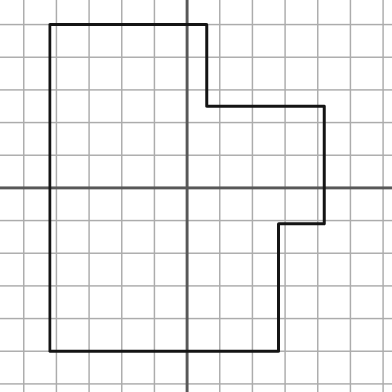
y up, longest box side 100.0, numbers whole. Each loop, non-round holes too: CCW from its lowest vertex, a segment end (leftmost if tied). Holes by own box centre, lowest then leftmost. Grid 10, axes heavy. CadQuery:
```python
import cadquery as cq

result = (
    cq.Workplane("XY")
    .moveTo(-42.0, -50.0)
    .lineTo(28.0, -50.0)
    .lineTo(28.0, -11.0)
    .lineTo(42.0, -11.0)
    .lineTo(42.0, 25.0)
    .lineTo(6.0, 25.0)
    .lineTo(6.0, 50.0)
    .lineTo(-42.0, 50.0)
    .close()
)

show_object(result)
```